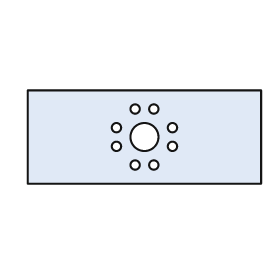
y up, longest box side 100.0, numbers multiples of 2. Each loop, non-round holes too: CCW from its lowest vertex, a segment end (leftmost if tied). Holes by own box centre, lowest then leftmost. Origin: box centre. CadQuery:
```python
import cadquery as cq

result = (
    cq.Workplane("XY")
    .moveTo(-50.0, -20.0)
    .lineTo(50.0, -20.0)
    .lineTo(50.0, 20.0)
    .lineTo(-50.0, 20.0)
    .close()
    .moveTo(-4.0, -12.0)
    .circle(2.0)
    .moveTo(4.0, -12.0)
    .circle(2.0)
    .moveTo(-12.0, -4.0)
    .circle(2.0)
    .moveTo(12.0, -4.0)
    .circle(2.0)
    .moveTo(0.0, 0.0)
    .circle(6.0)
    .moveTo(-12.0, 4.0)
    .circle(2.0)
    .moveTo(12.0, 4.0)
    .circle(2.0)
    .moveTo(-4.0, 12.0)
    .circle(2.0)
    .moveTo(4.0, 12.0)
    .circle(2.0)
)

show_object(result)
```